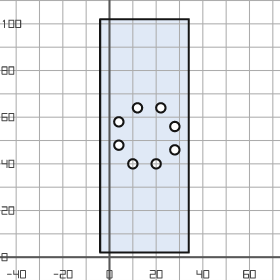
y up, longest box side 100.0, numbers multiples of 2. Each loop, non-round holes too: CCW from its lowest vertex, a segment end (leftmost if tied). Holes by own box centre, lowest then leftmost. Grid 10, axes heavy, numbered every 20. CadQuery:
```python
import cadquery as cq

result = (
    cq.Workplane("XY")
    .moveTo(-4.0, 2.0)
    .lineTo(34.0, 2.0)
    .lineTo(34.0, 102.0)
    .lineTo(-4.0, 102.0)
    .close()
    .moveTo(10.0, 40.0)
    .circle(2.0)
    .moveTo(20.0, 40.0)
    .circle(2.0)
    .moveTo(28.0, 46.0)
    .circle(2.0)
    .moveTo(4.0, 48.0)
    .circle(2.0)
    .moveTo(28.0, 56.0)
    .circle(2.0)
    .moveTo(4.0, 58.0)
    .circle(2.0)
    .moveTo(12.0, 64.0)
    .circle(2.0)
    .moveTo(22.0, 64.0)
    .circle(2.0)
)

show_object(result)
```